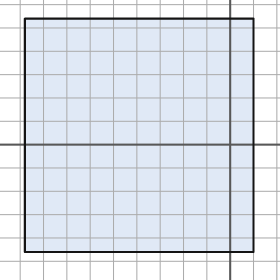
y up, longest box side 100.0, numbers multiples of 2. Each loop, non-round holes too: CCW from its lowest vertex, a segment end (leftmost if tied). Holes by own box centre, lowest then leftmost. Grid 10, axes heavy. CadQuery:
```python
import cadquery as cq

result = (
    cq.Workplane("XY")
    .moveTo(-88.0, -46.0)
    .lineTo(10.0, -46.0)
    .lineTo(10.0, 54.0)
    .lineTo(-88.0, 54.0)
    .close()
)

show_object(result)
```